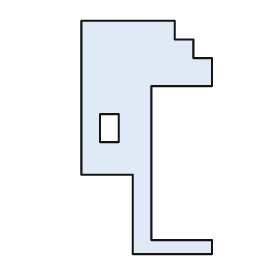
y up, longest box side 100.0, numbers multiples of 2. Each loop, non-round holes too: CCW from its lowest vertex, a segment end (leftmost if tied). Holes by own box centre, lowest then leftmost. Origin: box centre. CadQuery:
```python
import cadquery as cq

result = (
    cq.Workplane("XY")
    .moveTo(-6.0, -50.0)
    .lineTo(28.0, -50.0)
    .lineTo(28.0, -44.0)
    .lineTo(2.0, -44.0)
    .lineTo(2.0, 22.0)
    .lineTo(28.0, 22.0)
    .lineTo(28.0, 34.0)
    .lineTo(20.0, 34.0)
    .lineTo(20.0, 42.0)
    .lineTo(12.0, 42.0)
    .lineTo(12.0, 50.0)
    .lineTo(-28.0, 50.0)
    .lineTo(-28.0, -16.0)
    .lineTo(-6.0, -16.0)
    .close()
    .moveTo(-20.0, -2.0)
    .lineTo(-12.0, -2.0)
    .lineTo(-12.0, 10.0)
    .lineTo(-20.0, 10.0)
    .close()
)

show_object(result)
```